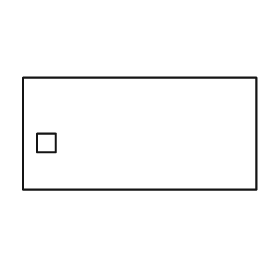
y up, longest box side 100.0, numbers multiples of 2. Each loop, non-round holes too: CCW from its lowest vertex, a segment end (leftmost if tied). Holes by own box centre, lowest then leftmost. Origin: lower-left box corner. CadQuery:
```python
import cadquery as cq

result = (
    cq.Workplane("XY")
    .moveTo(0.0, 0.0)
    .lineTo(100.0, 0.0)
    .lineTo(100.0, 48.0)
    .lineTo(0.0, 48.0)
    .close()
    .moveTo(6.0, 16.0)
    .lineTo(14.0, 16.0)
    .lineTo(14.0, 24.0)
    .lineTo(6.0, 24.0)
    .close()
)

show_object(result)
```